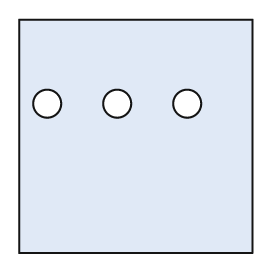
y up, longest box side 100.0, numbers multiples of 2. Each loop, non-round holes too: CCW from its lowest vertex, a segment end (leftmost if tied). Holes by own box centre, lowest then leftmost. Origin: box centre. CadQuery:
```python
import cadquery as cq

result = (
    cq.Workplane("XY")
    .moveTo(-50.0, -50.0)
    .lineTo(50.0, -50.0)
    .lineTo(50.0, 50.0)
    .lineTo(-50.0, 50.0)
    .close()
    .moveTo(-38.0, 14.0)
    .circle(6.0)
    .moveTo(-8.0, 14.0)
    .circle(6.0)
    .moveTo(22.0, 14.0)
    .circle(6.0)
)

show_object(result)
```